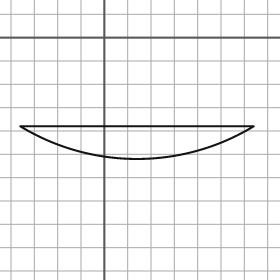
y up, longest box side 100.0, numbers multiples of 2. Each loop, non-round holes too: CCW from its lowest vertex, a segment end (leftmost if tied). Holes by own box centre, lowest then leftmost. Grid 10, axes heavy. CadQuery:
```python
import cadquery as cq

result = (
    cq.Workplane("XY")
    .moveTo(-36.0, -38.0)
    .threePointArc((14.0, -52.0), (64.0, -38.0))
    .close()
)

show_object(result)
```